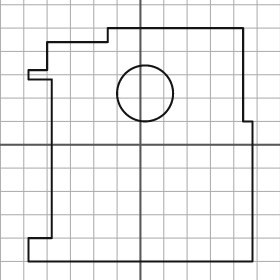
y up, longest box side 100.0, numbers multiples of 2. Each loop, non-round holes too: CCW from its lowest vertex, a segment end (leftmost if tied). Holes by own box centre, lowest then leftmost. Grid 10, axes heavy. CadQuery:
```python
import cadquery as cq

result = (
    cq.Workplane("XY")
    .moveTo(-48.0, -50.0)
    .lineTo(48.0, -50.0)
    .lineTo(48.0, 10.0)
    .lineTo(44.0, 10.0)
    .lineTo(44.0, 50.0)
    .lineTo(-14.0, 50.0)
    .lineTo(-14.0, 44.0)
    .lineTo(-40.0, 44.0)
    .lineTo(-40.0, 32.0)
    .lineTo(-48.0, 32.0)
    .lineTo(-48.0, 28.0)
    .lineTo(-38.0, 28.0)
    .lineTo(-38.0, -40.0)
    .lineTo(-48.0, -40.0)
    .close()
    .moveTo(2.0, 22.0)
    .circle(12.0)
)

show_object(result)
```